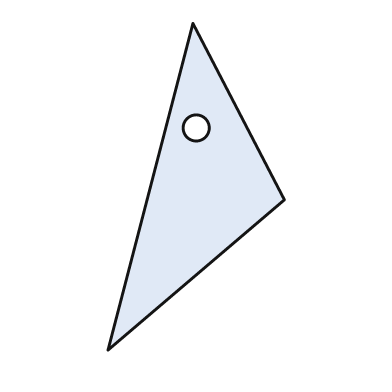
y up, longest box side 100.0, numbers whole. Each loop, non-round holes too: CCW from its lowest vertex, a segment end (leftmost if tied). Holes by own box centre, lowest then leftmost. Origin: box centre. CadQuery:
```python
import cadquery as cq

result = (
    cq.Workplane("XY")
    .moveTo(-27.0, -50.0)
    .lineTo(27.0, -4.0)
    .lineTo(-1.0, 50.0)
    .close()
    .moveTo(0.0, 18.0)
    .circle(4.0)
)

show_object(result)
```